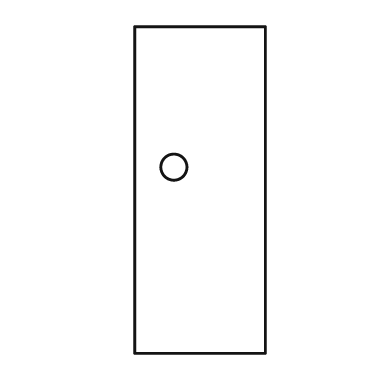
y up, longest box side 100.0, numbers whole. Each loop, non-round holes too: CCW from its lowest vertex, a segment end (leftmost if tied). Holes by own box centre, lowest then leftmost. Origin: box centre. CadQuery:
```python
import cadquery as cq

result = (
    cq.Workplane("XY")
    .moveTo(-20.0, -50.0)
    .lineTo(20.0, -50.0)
    .lineTo(20.0, 50.0)
    .lineTo(-20.0, 50.0)
    .close()
    .moveTo(-8.0, 7.0)
    .circle(4.0)
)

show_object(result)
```